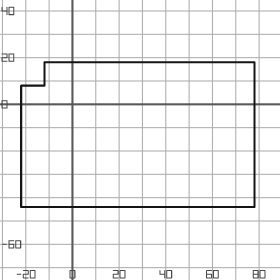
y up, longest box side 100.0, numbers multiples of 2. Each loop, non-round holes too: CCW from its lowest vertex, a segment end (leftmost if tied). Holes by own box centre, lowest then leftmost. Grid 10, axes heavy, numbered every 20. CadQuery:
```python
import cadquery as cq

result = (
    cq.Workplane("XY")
    .moveTo(-22.0, -44.0)
    .lineTo(78.0, -44.0)
    .lineTo(78.0, 18.0)
    .lineTo(-12.0, 18.0)
    .lineTo(-12.0, 8.0)
    .lineTo(-22.0, 8.0)
    .close()
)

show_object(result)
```